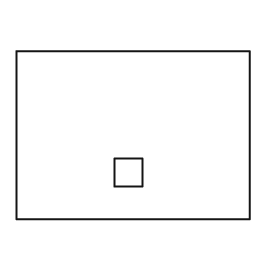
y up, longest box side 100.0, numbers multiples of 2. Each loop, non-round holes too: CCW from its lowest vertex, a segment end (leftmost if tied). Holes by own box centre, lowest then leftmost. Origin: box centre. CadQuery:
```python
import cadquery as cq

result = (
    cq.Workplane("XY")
    .moveTo(-50.0, -36.0)
    .lineTo(50.0, -36.0)
    .lineTo(50.0, 36.0)
    .lineTo(-50.0, 36.0)
    .close()
    .moveTo(-8.0, -22.0)
    .lineTo(4.0, -22.0)
    .lineTo(4.0, -10.0)
    .lineTo(-8.0, -10.0)
    .close()
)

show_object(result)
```